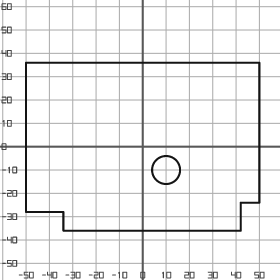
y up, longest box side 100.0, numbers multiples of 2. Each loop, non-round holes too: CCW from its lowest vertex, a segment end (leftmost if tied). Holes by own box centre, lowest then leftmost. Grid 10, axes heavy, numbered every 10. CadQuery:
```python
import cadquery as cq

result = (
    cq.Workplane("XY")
    .moveTo(-34.0, -36.0)
    .lineTo(42.0, -36.0)
    .lineTo(42.0, -24.0)
    .lineTo(50.0, -24.0)
    .lineTo(50.0, 36.0)
    .lineTo(-50.0, 36.0)
    .lineTo(-50.0, -28.0)
    .lineTo(-34.0, -28.0)
    .close()
    .moveTo(10.0, -10.0)
    .circle(6.0)
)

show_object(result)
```